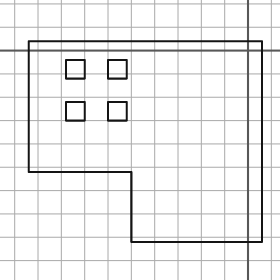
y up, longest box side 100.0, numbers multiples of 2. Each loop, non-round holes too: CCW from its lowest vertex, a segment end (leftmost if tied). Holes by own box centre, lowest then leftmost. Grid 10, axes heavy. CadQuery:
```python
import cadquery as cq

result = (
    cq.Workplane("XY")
    .moveTo(-50.0, -82.0)
    .lineTo(6.0, -82.0)
    .lineTo(6.0, 4.0)
    .lineTo(-94.0, 4.0)
    .lineTo(-94.0, -52.0)
    .lineTo(-50.0, -52.0)
    .close()
    .moveTo(-78.0, -30.0)
    .lineTo(-70.0, -30.0)
    .lineTo(-70.0, -22.0)
    .lineTo(-78.0, -22.0)
    .close()
    .moveTo(-60.0, -30.0)
    .lineTo(-52.0, -30.0)
    .lineTo(-52.0, -22.0)
    .lineTo(-60.0, -22.0)
    .close()
    .moveTo(-78.0, -12.0)
    .lineTo(-70.0, -12.0)
    .lineTo(-70.0, -4.0)
    .lineTo(-78.0, -4.0)
    .close()
    .moveTo(-60.0, -12.0)
    .lineTo(-52.0, -12.0)
    .lineTo(-52.0, -4.0)
    .lineTo(-60.0, -4.0)
    .close()
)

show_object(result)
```